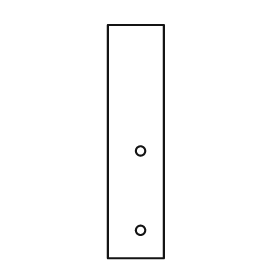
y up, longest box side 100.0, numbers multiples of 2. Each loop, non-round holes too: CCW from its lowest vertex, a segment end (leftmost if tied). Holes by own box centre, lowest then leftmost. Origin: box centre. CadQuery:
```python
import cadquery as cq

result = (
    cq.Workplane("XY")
    .moveTo(-12.0, -50.0)
    .lineTo(12.0, -50.0)
    .lineTo(12.0, 50.0)
    .lineTo(-12.0, 50.0)
    .close()
    .moveTo(2.0, -38.0)
    .circle(2.0)
    .moveTo(2.0, -4.0)
    .circle(2.0)
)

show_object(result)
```